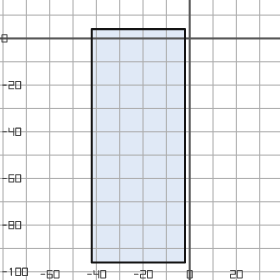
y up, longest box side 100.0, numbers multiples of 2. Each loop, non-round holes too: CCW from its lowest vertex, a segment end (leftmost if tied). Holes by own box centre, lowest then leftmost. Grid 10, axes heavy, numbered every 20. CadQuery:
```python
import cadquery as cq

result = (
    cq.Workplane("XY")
    .moveTo(-42.0, -96.0)
    .lineTo(-2.0, -96.0)
    .lineTo(-2.0, 4.0)
    .lineTo(-42.0, 4.0)
    .close()
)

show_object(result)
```